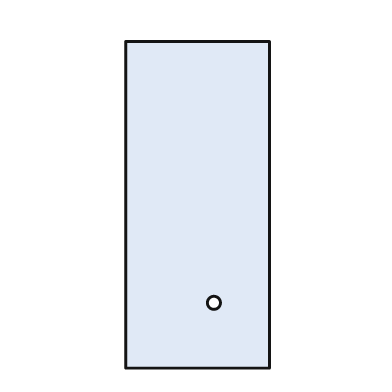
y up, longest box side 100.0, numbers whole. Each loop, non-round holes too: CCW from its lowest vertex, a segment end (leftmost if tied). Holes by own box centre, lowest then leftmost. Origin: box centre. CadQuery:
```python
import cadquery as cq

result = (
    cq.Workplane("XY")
    .moveTo(-22.0, -50.0)
    .lineTo(22.0, -50.0)
    .lineTo(22.0, 50.0)
    .lineTo(-22.0, 50.0)
    .close()
    .moveTo(5.0, -30.0)
    .circle(2.0)
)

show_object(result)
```